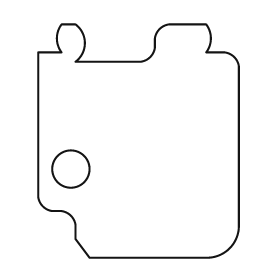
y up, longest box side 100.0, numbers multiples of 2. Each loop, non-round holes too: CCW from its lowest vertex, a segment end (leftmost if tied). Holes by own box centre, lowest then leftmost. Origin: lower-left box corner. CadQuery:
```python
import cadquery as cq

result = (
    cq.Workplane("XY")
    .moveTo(22.0, 0.0)
    .lineTo(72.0, 0.0)
    .threePointArc((82.0, 4.0), (86.0, 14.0))
    .lineTo(86.0, 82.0)
    .threePointArc((84.0, 86.0), (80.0, 88.0))
    .lineTo(72.0, 88.0)
    .threePointArc((74.0, 94.0), (72.0, 100.0))
    .lineTo(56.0, 100.0)
    .threePointArc((52.0, 98.0), (50.0, 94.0))
    .lineTo(50.0, 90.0)
    .threePointArc((48.0, 86.0), (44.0, 84.0))
    .lineTo(16.0, 84.0)
    .threePointArc((20.0, 92.0), (16.0, 100.0))
    .lineTo(10.0, 100.0)
    .threePointArc((8.0, 94.0), (10.0, 88.0))
    .lineTo(0.0, 88.0)
    .lineTo(0.0, 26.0)
    .threePointArc((2.0, 22.0), (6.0, 20.0))
    .lineTo(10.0, 20.0)
    .threePointArc((14.0, 18.0), (16.0, 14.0))
    .lineTo(16.0, 8.0)
    .close()
    .moveTo(14.0, 38.0)
    .circle(8.0)
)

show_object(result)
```